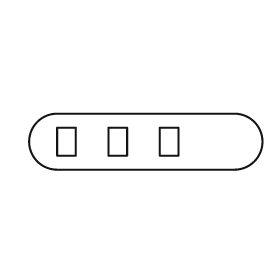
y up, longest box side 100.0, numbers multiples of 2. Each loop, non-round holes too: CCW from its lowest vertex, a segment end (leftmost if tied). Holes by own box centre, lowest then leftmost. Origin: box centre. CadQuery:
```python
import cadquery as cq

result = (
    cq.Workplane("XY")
    .moveTo(-38.0, -12.0)
    .lineTo(38.0, -12.0)
    .threePointArc((50.0, 0.0), (38.0, 12.0))
    .lineTo(-38.0, 12.0)
    .threePointArc((-50.0, 0.0), (-38.0, -12.0))
    .close()
    .moveTo(-38.0, -6.0)
    .lineTo(-30.0, -6.0)
    .lineTo(-30.0, 6.0)
    .lineTo(-38.0, 6.0)
    .close()
    .moveTo(-16.0, -6.0)
    .lineTo(-8.0, -6.0)
    .lineTo(-8.0, 6.0)
    .lineTo(-16.0, 6.0)
    .close()
    .moveTo(6.0, -6.0)
    .lineTo(14.0, -6.0)
    .lineTo(14.0, 6.0)
    .lineTo(6.0, 6.0)
    .close()
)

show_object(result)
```